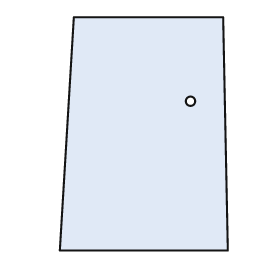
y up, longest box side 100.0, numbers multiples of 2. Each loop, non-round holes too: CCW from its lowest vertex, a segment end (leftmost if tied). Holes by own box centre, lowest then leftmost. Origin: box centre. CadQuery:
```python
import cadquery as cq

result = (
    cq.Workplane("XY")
    .moveTo(-36.0, -50.0)
    .lineTo(36.0, -50.0)
    .lineTo(34.0, 50.0)
    .lineTo(-30.0, 50.0)
    .close()
    .moveTo(20.0, 14.0)
    .circle(2.0)
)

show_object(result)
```